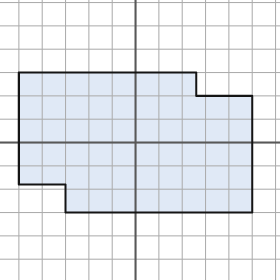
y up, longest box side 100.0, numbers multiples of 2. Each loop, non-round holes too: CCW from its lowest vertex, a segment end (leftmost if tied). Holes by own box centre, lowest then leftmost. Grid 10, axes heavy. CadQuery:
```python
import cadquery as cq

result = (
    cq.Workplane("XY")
    .moveTo(-30.0, -30.0)
    .lineTo(50.0, -30.0)
    .lineTo(50.0, 20.0)
    .lineTo(26.0, 20.0)
    .lineTo(26.0, 30.0)
    .lineTo(-50.0, 30.0)
    .lineTo(-50.0, -18.0)
    .lineTo(-30.0, -18.0)
    .close()
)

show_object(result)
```